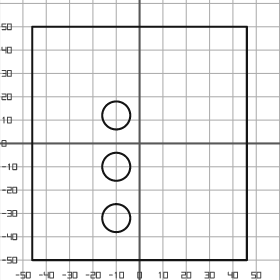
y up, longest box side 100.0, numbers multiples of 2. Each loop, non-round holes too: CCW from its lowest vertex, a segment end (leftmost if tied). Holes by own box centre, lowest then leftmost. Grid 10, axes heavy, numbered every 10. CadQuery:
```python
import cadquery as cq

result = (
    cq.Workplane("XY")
    .moveTo(-46.0, -50.0)
    .lineTo(46.0, -50.0)
    .lineTo(46.0, 50.0)
    .lineTo(-46.0, 50.0)
    .close()
    .moveTo(-10.0, -32.0)
    .circle(6.0)
    .moveTo(-10.0, -10.0)
    .circle(6.0)
    .moveTo(-10.0, 12.0)
    .circle(6.0)
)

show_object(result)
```